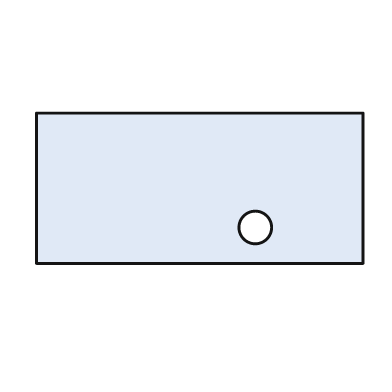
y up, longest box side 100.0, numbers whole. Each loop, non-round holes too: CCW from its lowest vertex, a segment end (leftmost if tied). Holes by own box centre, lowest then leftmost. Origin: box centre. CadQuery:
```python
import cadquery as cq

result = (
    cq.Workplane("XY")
    .moveTo(-50.0, -23.0)
    .lineTo(50.0, -23.0)
    .lineTo(50.0, 23.0)
    .lineTo(-50.0, 23.0)
    .close()
    .moveTo(17.0, -12.0)
    .circle(5.0)
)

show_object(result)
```